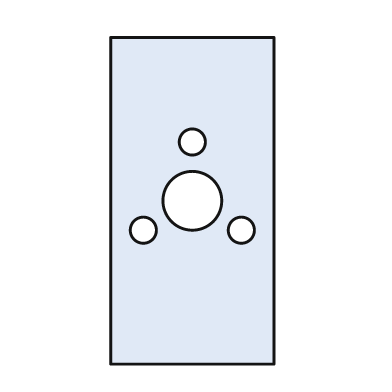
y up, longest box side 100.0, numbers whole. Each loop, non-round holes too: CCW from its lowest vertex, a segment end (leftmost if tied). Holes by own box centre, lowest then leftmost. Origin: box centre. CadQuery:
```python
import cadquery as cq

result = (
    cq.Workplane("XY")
    .moveTo(-25.0, -50.0)
    .lineTo(25.0, -50.0)
    .lineTo(25.0, 50.0)
    .lineTo(-25.0, 50.0)
    .close()
    .moveTo(-15.0, -9.0)
    .circle(4.0)
    .moveTo(15.0, -9.0)
    .circle(4.0)
    .moveTo(0.0, 0.0)
    .circle(9.0)
    .moveTo(0.0, 18.0)
    .circle(4.0)
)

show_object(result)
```